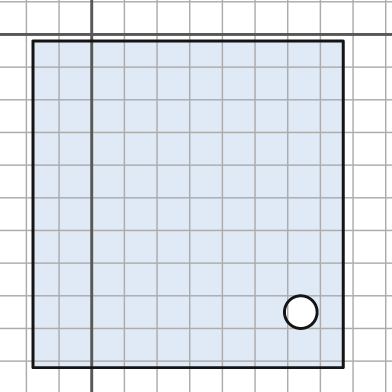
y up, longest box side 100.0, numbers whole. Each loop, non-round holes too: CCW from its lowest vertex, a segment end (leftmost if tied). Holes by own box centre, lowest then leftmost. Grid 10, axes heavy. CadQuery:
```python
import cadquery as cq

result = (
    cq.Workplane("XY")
    .moveTo(-18.0, -102.0)
    .lineTo(77.0, -102.0)
    .lineTo(77.0, -2.0)
    .lineTo(-18.0, -2.0)
    .close()
    .moveTo(64.0, -85.0)
    .circle(5.0)
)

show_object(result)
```